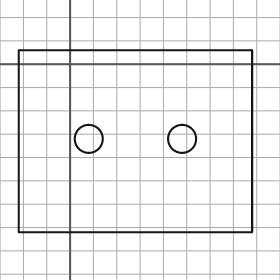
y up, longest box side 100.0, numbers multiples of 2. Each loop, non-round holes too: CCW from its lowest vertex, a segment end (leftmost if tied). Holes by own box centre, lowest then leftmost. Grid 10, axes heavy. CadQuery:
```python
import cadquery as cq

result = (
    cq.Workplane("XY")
    .moveTo(-22.0, -72.0)
    .lineTo(78.0, -72.0)
    .lineTo(78.0, 6.0)
    .lineTo(-22.0, 6.0)
    .close()
    .moveTo(8.0, -32.0)
    .circle(6.0)
    .moveTo(48.0, -32.0)
    .circle(6.0)
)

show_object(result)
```